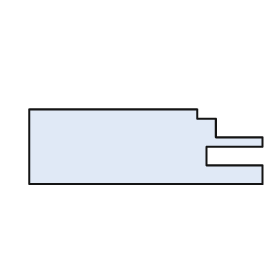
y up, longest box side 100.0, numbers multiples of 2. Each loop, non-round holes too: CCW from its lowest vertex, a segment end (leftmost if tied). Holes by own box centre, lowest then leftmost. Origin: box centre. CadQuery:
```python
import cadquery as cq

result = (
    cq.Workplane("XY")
    .moveTo(-50.0, -16.0)
    .lineTo(50.0, -16.0)
    .lineTo(50.0, -8.0)
    .lineTo(26.0, -8.0)
    .lineTo(26.0, 0.0)
    .lineTo(50.0, 0.0)
    .lineTo(50.0, 4.0)
    .lineTo(30.0, 4.0)
    .lineTo(30.0, 12.0)
    .lineTo(22.0, 12.0)
    .lineTo(22.0, 16.0)
    .lineTo(-50.0, 16.0)
    .close()
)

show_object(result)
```